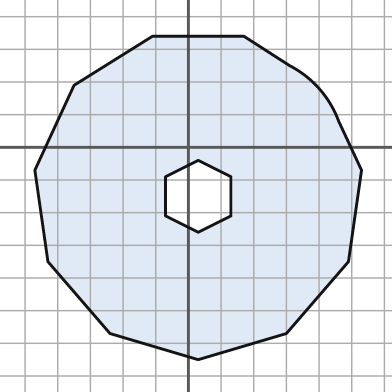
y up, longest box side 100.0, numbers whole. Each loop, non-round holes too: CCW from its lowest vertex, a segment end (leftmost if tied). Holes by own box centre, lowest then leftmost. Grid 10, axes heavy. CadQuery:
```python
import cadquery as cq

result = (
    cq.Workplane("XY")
    .moveTo(3.0, -65.0)
    .lineTo(30.0, -57.0)
    .lineTo(49.0, -35.0)
    .lineTo(53.0, -7.0)
    .lineTo(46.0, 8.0)
    .threePointArc((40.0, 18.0), (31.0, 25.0))
    .lineTo(17.0, 34.0)
    .lineTo(-11.0, 34.0)
    .lineTo(-35.0, 19.0)
    .lineTo(-47.0, -7.0)
    .lineTo(-43.0, -35.0)
    .lineTo(-24.0, -57.0)
    .close()
    .moveTo(3.0, -26.0)
    .lineTo(13.0, -21.0)
    .lineTo(13.0, -9.0)
    .lineTo(3.0, -4.0)
    .lineTo(-7.0, -9.0)
    .lineTo(-7.0, -21.0)
    .close()
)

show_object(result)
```